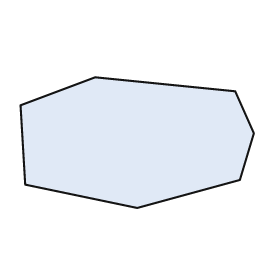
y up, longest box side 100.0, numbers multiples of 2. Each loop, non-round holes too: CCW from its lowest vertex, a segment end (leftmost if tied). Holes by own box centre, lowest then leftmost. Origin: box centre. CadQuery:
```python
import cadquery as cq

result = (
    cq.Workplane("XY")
    .moveTo(0.0, -28.0)
    .lineTo(44.0, -16.0)
    .lineTo(50.0, 4.0)
    .lineTo(42.0, 22.0)
    .lineTo(-18.0, 28.0)
    .lineTo(-50.0, 16.0)
    .lineTo(-48.0, -18.0)
    .close()
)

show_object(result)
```